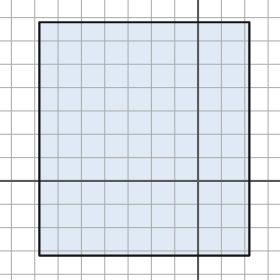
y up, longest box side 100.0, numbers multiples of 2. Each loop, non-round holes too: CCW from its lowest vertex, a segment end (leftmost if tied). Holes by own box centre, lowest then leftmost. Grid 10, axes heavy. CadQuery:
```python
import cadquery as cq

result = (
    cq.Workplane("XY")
    .moveTo(-68.0, -32.0)
    .lineTo(22.0, -32.0)
    .lineTo(22.0, 68.0)
    .lineTo(-68.0, 68.0)
    .close()
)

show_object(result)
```